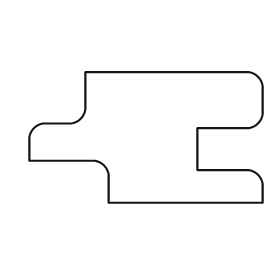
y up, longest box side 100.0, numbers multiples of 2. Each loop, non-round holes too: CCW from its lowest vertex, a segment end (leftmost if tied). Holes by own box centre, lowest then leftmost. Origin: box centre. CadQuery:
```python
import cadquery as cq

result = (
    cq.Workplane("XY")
    .moveTo(-16.0, -28.0)
    .lineTo(50.0, -28.0)
    .lineTo(50.0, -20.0)
    .threePointArc((48.0, -16.0), (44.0, -14.0))
    .lineTo(22.0, -14.0)
    .lineTo(22.0, 4.0)
    .lineTo(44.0, 4.0)
    .threePointArc((48.0, 6.0), (50.0, 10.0))
    .lineTo(50.0, 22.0)
    .threePointArc((48.0, 26.0), (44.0, 28.0))
    .lineTo(-26.0, 28.0)
    .lineTo(-26.0, 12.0)
    .threePointArc((-28.0, 8.0), (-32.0, 6.0))
    .lineTo(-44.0, 6.0)
    .threePointArc((-48.0, 4.0), (-50.0, 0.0))
    .lineTo(-50.0, -10.0)
    .lineTo(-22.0, -10.0)
    .threePointArc((-18.0, -12.0), (-16.0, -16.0))
    .close()
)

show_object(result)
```